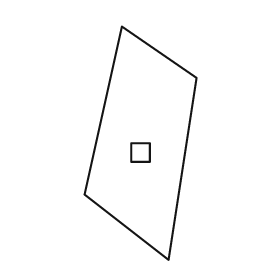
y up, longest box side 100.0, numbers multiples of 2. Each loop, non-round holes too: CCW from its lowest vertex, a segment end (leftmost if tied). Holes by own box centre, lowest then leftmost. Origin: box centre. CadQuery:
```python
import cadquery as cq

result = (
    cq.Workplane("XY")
    .moveTo(12.0, -50.0)
    .lineTo(24.0, 28.0)
    .lineTo(-8.0, 50.0)
    .lineTo(-24.0, -22.0)
    .close()
    .moveTo(-4.0, -8.0)
    .lineTo(4.0, -8.0)
    .lineTo(4.0, 0.0)
    .lineTo(-4.0, 0.0)
    .close()
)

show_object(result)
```